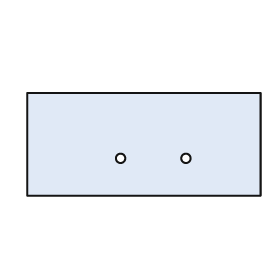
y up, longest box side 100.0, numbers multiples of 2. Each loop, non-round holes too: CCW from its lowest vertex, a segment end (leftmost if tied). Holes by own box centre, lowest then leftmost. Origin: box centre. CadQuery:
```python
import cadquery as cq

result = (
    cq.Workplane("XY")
    .moveTo(-50.0, -22.0)
    .lineTo(50.0, -22.0)
    .lineTo(50.0, 22.0)
    .lineTo(-50.0, 22.0)
    .close()
    .moveTo(-10.0, -6.0)
    .circle(2.0)
    .moveTo(18.0, -6.0)
    .circle(2.0)
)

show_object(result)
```